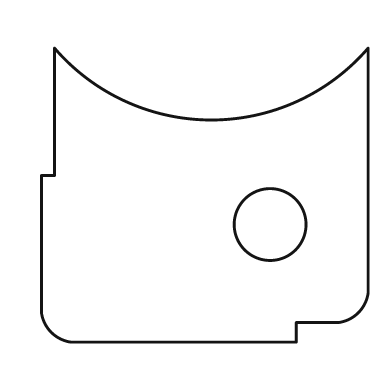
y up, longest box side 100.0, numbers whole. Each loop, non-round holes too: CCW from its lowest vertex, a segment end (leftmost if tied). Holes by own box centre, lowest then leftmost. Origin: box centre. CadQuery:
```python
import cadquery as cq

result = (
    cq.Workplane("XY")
    .moveTo(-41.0, -45.0)
    .lineTo(28.0, -45.0)
    .lineTo(28.0, -39.0)
    .lineTo(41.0, -39.0)
    .threePointArc((47.0, -36.0), (50.0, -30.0))
    .lineTo(50.0, 45.0)
    .threePointArc((2.0, 23.0), (-46.0, 45.0))
    .lineTo(-46.0, 6.0)
    .lineTo(-50.0, 6.0)
    .lineTo(-50.0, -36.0)
    .threePointArc((-47.0, -42.0), (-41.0, -45.0))
    .close()
    .moveTo(20.0, -9.0)
    .circle(11.0)
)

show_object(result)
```